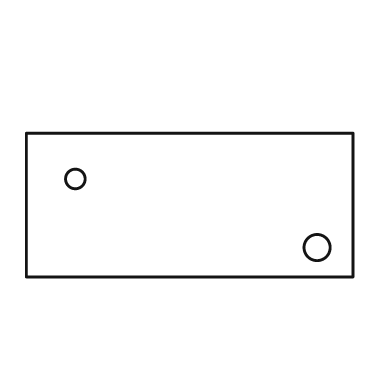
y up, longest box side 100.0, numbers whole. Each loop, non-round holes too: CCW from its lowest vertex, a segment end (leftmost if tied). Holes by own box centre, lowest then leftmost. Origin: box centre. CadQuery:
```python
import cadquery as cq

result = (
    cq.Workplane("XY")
    .moveTo(-50.0, -22.0)
    .lineTo(50.0, -22.0)
    .lineTo(50.0, 22.0)
    .lineTo(-50.0, 22.0)
    .close()
    .moveTo(39.0, -13.0)
    .circle(4.0)
    .moveTo(-35.0, 8.0)
    .circle(3.0)
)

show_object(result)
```